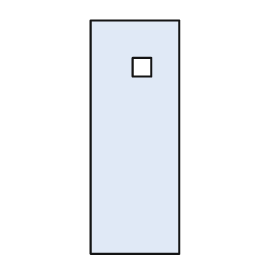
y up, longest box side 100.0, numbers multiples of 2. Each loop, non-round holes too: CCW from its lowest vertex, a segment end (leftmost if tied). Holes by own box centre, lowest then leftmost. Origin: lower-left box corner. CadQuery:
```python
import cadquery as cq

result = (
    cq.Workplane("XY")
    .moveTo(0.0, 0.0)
    .lineTo(38.0, 0.0)
    .lineTo(38.0, 100.0)
    .lineTo(0.0, 100.0)
    .close()
    .moveTo(18.0, 76.0)
    .lineTo(26.0, 76.0)
    .lineTo(26.0, 84.0)
    .lineTo(18.0, 84.0)
    .close()
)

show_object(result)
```